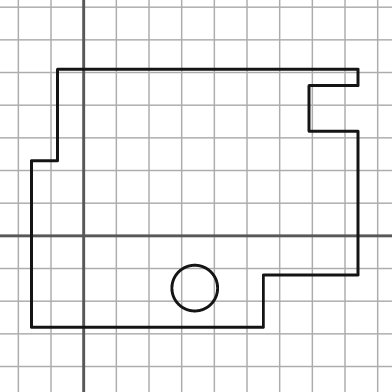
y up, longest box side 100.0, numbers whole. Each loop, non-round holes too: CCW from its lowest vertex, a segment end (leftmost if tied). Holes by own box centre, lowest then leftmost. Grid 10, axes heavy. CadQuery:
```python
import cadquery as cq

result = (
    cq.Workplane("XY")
    .moveTo(-16.0, -28.0)
    .lineTo(55.0, -28.0)
    .lineTo(55.0, -12.0)
    .lineTo(84.0, -12.0)
    .lineTo(84.0, 32.0)
    .lineTo(69.0, 32.0)
    .lineTo(69.0, 46.0)
    .lineTo(84.0, 46.0)
    .lineTo(84.0, 51.0)
    .lineTo(-8.0, 51.0)
    .lineTo(-8.0, 23.0)
    .lineTo(-16.0, 23.0)
    .close()
    .moveTo(34.0, -16.0)
    .circle(7.0)
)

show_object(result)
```